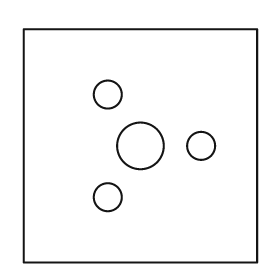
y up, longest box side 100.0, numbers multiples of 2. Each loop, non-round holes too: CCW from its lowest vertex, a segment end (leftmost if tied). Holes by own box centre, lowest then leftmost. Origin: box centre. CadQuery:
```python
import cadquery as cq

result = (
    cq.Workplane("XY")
    .moveTo(-50.0, -50.0)
    .lineTo(50.0, -50.0)
    .lineTo(50.0, 50.0)
    .lineTo(-50.0, 50.0)
    .close()
    .moveTo(-14.0, -22.0)
    .circle(6.0)
    .moveTo(0.0, 0.0)
    .circle(10.0)
    .moveTo(26.0, 0.0)
    .circle(6.0)
    .moveTo(-14.0, 22.0)
    .circle(6.0)
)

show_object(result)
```